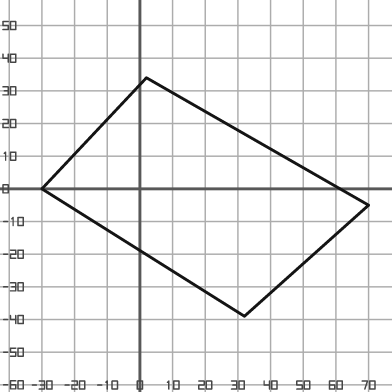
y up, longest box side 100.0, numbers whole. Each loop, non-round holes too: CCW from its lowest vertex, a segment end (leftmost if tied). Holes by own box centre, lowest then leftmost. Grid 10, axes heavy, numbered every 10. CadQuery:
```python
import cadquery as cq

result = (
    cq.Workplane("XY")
    .moveTo(32.0, -39.0)
    .lineTo(70.0, -5.0)
    .lineTo(2.0, 34.0)
    .lineTo(-30.0, 0.0)
    .close()
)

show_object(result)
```